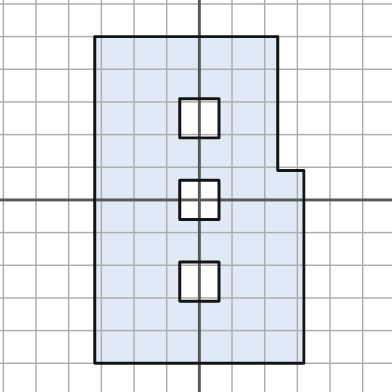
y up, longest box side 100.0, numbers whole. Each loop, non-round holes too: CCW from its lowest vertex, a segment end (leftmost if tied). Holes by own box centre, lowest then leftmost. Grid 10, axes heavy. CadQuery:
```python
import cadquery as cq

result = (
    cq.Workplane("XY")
    .moveTo(-32.0, -50.0)
    .lineTo(32.0, -50.0)
    .lineTo(32.0, 9.0)
    .lineTo(24.0, 9.0)
    .lineTo(24.0, 50.0)
    .lineTo(-32.0, 50.0)
    .close()
    .moveTo(-6.0, -31.0)
    .lineTo(6.0, -31.0)
    .lineTo(6.0, -19.0)
    .lineTo(-6.0, -19.0)
    .close()
    .moveTo(-6.0, -6.0)
    .lineTo(6.0, -6.0)
    .lineTo(6.0, 6.0)
    .lineTo(-6.0, 6.0)
    .close()
    .moveTo(-6.0, 19.0)
    .lineTo(6.0, 19.0)
    .lineTo(6.0, 31.0)
    .lineTo(-6.0, 31.0)
    .close()
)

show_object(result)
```